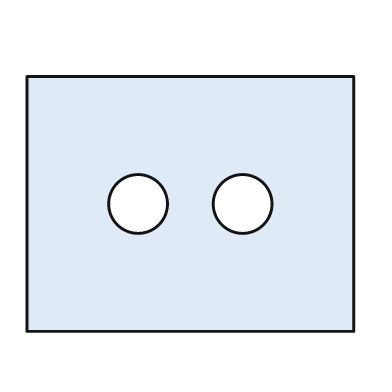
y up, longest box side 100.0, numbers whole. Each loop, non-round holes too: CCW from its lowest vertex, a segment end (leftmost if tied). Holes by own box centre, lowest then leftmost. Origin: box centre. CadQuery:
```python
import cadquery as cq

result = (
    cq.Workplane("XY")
    .moveTo(-50.0, -39.0)
    .lineTo(50.0, -39.0)
    .lineTo(50.0, 39.0)
    .lineTo(-50.0, 39.0)
    .close()
    .moveTo(-16.0, 0.0)
    .circle(9.0)
    .moveTo(16.0, 0.0)
    .circle(9.0)
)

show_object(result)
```